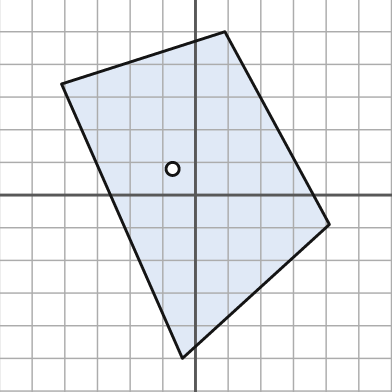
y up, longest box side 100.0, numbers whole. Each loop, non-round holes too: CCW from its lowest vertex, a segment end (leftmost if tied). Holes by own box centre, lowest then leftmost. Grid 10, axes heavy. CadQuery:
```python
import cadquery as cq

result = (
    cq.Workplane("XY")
    .moveTo(-4.0, -50.0)
    .lineTo(41.0, -9.0)
    .lineTo(9.0, 50.0)
    .lineTo(-41.0, 34.0)
    .close()
    .moveTo(-7.0, 8.0)
    .circle(2.0)
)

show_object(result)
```